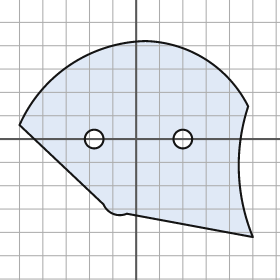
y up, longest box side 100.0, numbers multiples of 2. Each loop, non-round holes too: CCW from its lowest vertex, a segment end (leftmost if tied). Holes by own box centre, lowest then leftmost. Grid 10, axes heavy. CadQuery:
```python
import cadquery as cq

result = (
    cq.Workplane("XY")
    .moveTo(50.0, -42.0)
    .threePointArc((44.0, -14.0), (48.0, 14.0))
    .threePointArc((30.0, 34.0), (4.0, 42.0))
    .threePointArc((-28.0, 32.0), (-50.0, 6.0))
    .lineTo(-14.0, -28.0)
    .threePointArc((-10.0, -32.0), (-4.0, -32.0))
    .close()
    .moveTo(-18.0, 0.0)
    .circle(4.0)
    .moveTo(20.0, 0.0)
    .circle(4.0)
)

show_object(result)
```